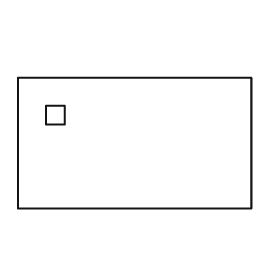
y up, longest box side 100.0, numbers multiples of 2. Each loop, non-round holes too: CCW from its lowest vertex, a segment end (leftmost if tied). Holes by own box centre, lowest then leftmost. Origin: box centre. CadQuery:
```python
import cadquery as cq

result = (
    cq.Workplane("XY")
    .moveTo(-50.0, -28.0)
    .lineTo(50.0, -28.0)
    .lineTo(50.0, 28.0)
    .lineTo(-50.0, 28.0)
    .close()
    .moveTo(-38.0, 8.0)
    .lineTo(-30.0, 8.0)
    .lineTo(-30.0, 16.0)
    .lineTo(-38.0, 16.0)
    .close()
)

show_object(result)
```